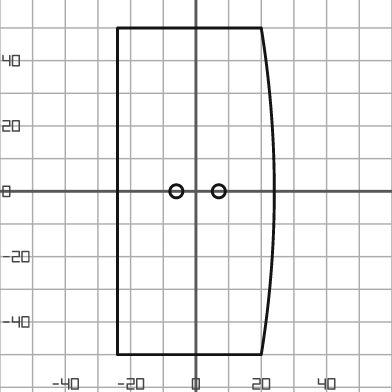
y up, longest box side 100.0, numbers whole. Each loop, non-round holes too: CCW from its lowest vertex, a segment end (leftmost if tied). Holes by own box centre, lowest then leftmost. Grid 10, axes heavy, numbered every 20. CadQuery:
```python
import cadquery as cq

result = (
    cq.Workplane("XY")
    .moveTo(-24.0, -50.0)
    .lineTo(20.0, -50.0)
    .threePointArc((24.0, 0.0), (20.0, 50.0))
    .lineTo(-24.0, 50.0)
    .close()
    .moveTo(-6.0, 0.0)
    .circle(2.0)
    .moveTo(7.0, 0.0)
    .circle(2.0)
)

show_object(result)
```